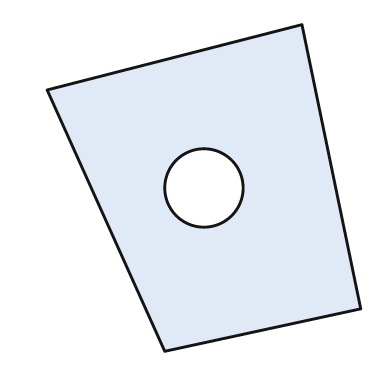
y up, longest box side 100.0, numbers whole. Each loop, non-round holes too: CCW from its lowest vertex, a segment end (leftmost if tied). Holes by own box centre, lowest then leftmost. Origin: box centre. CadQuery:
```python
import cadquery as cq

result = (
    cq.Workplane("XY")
    .moveTo(-12.0, -50.0)
    .lineTo(48.0, -37.0)
    .lineTo(30.0, 50.0)
    .lineTo(-48.0, 30.0)
    .close()
    .moveTo(0.0, 0.0)
    .circle(12.0)
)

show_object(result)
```